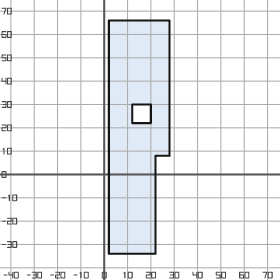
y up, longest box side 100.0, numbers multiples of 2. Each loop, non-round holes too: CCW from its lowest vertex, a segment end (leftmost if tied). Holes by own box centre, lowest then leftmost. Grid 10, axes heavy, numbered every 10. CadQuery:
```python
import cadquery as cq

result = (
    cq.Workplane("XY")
    .moveTo(2.0, -34.0)
    .lineTo(22.0, -34.0)
    .lineTo(22.0, 8.0)
    .lineTo(28.0, 8.0)
    .lineTo(28.0, 66.0)
    .lineTo(2.0, 66.0)
    .close()
    .moveTo(12.0, 22.0)
    .lineTo(20.0, 22.0)
    .lineTo(20.0, 30.0)
    .lineTo(12.0, 30.0)
    .close()
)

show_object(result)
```